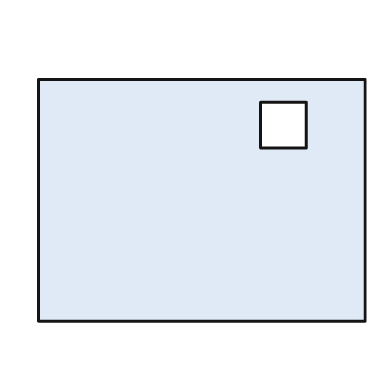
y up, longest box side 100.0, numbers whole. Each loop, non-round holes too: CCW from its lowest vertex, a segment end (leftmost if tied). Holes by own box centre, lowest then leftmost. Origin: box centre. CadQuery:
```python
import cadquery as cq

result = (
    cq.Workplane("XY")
    .moveTo(-50.0, -37.0)
    .lineTo(50.0, -37.0)
    .lineTo(50.0, 37.0)
    .lineTo(-50.0, 37.0)
    .close()
    .moveTo(18.0, 16.0)
    .lineTo(32.0, 16.0)
    .lineTo(32.0, 30.0)
    .lineTo(18.0, 30.0)
    .close()
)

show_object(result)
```